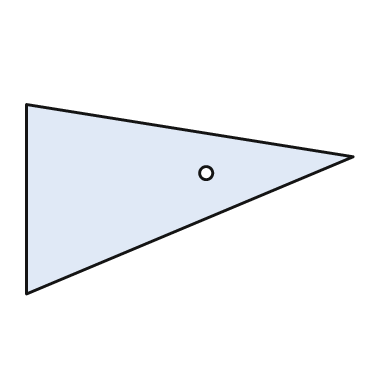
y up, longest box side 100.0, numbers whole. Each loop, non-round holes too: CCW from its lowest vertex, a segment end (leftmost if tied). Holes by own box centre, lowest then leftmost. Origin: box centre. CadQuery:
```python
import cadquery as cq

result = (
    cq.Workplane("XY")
    .moveTo(-50.0, -29.0)
    .lineTo(50.0, 13.0)
    .lineTo(-50.0, 29.0)
    .close()
    .moveTo(5.0, 8.0)
    .circle(2.0)
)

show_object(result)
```